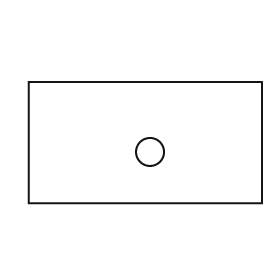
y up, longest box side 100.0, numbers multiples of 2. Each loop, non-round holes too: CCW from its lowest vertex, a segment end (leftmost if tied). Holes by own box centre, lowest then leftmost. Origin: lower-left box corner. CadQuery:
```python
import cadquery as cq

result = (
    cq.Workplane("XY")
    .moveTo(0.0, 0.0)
    .lineTo(100.0, 0.0)
    .lineTo(100.0, 52.0)
    .lineTo(0.0, 52.0)
    .close()
    .moveTo(52.0, 22.0)
    .circle(6.0)
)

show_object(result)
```